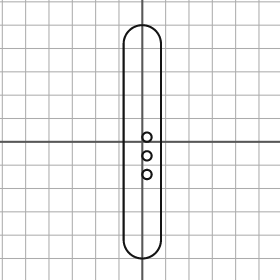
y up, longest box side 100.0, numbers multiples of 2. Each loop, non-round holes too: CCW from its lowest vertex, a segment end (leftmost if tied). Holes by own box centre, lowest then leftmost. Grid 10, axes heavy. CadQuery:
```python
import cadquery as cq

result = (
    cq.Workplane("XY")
    .moveTo(-8.0, -42.0)
    .threePointArc((0.0, -50.0), (8.0, -42.0))
    .lineTo(8.0, 42.0)
    .threePointArc((0.0, 50.0), (-8.0, 42.0))
    .close()
    .moveTo(2.0, -14.0)
    .circle(2.0)
    .moveTo(2.0, -6.0)
    .circle(2.0)
    .moveTo(2.0, 2.0)
    .circle(2.0)
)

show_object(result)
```